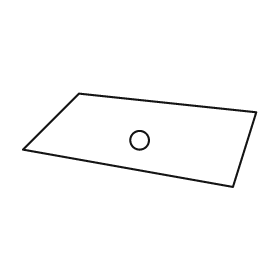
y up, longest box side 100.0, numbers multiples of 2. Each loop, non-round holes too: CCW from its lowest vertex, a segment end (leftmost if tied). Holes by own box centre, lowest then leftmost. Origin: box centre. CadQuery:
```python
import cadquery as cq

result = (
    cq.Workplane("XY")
    .moveTo(40.0, -20.0)
    .lineTo(50.0, 12.0)
    .lineTo(-26.0, 20.0)
    .lineTo(-50.0, -4.0)
    .close()
    .moveTo(0.0, 0.0)
    .circle(4.0)
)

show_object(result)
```